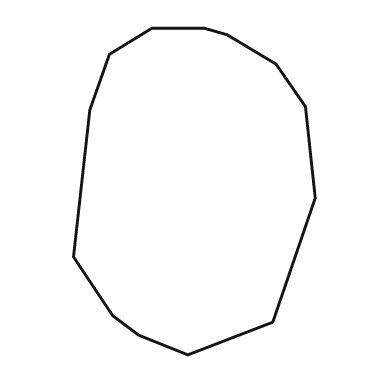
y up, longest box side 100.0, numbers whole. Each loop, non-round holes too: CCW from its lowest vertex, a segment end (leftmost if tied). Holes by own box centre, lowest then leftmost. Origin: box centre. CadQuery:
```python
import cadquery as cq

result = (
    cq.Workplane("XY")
    .moveTo(-2.0, -50.0)
    .lineTo(24.0, -40.0)
    .lineTo(37.0, -2.0)
    .lineTo(34.0, 26.0)
    .lineTo(25.0, 39.0)
    .lineTo(10.0, 48.0)
    .lineTo(3.0, 50.0)
    .lineTo(-13.0, 50.0)
    .lineTo(-26.0, 42.0)
    .lineTo(-32.0, 25.0)
    .lineTo(-37.0, -20.0)
    .lineTo(-25.0, -38.0)
    .lineTo(-17.0, -44.0)
    .close()
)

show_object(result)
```